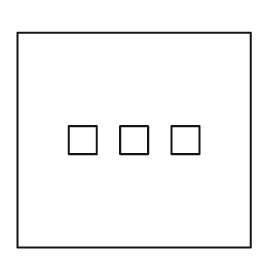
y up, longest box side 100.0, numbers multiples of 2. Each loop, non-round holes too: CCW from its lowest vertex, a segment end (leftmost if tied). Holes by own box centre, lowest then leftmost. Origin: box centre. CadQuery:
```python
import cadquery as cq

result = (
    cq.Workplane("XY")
    .moveTo(-50.0, -46.0)
    .lineTo(50.0, -46.0)
    .lineTo(50.0, 46.0)
    .lineTo(-50.0, 46.0)
    .close()
    .moveTo(-28.0, -6.0)
    .lineTo(-16.0, -6.0)
    .lineTo(-16.0, 6.0)
    .lineTo(-28.0, 6.0)
    .close()
    .moveTo(-6.0, -6.0)
    .lineTo(6.0, -6.0)
    .lineTo(6.0, 6.0)
    .lineTo(-6.0, 6.0)
    .close()
    .moveTo(16.0, -6.0)
    .lineTo(28.0, -6.0)
    .lineTo(28.0, 6.0)
    .lineTo(16.0, 6.0)
    .close()
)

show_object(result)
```